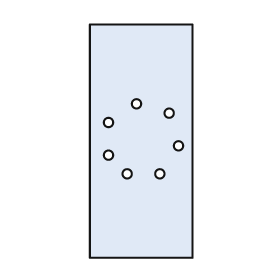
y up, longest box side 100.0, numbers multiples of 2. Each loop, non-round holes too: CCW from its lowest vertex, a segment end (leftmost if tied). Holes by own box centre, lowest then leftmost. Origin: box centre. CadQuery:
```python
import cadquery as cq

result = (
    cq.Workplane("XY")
    .moveTo(-22.0, -50.0)
    .lineTo(22.0, -50.0)
    .lineTo(22.0, 50.0)
    .lineTo(-22.0, 50.0)
    .close()
    .moveTo(-6.0, -14.0)
    .circle(2.0)
    .moveTo(8.0, -14.0)
    .circle(2.0)
    .moveTo(-14.0, -6.0)
    .circle(2.0)
    .moveTo(16.0, -2.0)
    .circle(2.0)
    .moveTo(-14.0, 8.0)
    .circle(2.0)
    .moveTo(12.0, 12.0)
    .circle(2.0)
    .moveTo(-2.0, 16.0)
    .circle(2.0)
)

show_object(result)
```